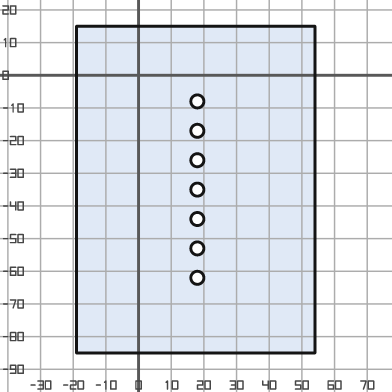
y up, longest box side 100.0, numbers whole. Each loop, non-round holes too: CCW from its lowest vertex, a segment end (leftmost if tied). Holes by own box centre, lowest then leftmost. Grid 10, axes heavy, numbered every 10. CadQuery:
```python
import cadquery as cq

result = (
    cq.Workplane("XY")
    .moveTo(-19.0, -85.0)
    .lineTo(54.0, -85.0)
    .lineTo(54.0, 15.0)
    .lineTo(-19.0, 15.0)
    .close()
    .moveTo(18.0, -62.0)
    .circle(2.0)
    .moveTo(18.0, -53.0)
    .circle(2.0)
    .moveTo(18.0, -44.0)
    .circle(2.0)
    .moveTo(18.0, -35.0)
    .circle(2.0)
    .moveTo(18.0, -26.0)
    .circle(2.0)
    .moveTo(18.0, -17.0)
    .circle(2.0)
    .moveTo(18.0, -8.0)
    .circle(2.0)
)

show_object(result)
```